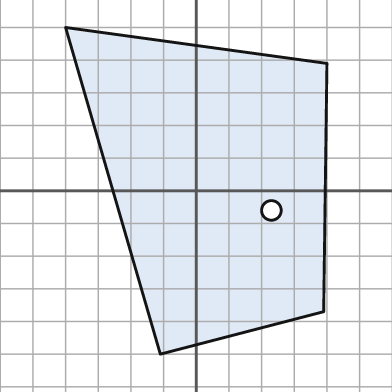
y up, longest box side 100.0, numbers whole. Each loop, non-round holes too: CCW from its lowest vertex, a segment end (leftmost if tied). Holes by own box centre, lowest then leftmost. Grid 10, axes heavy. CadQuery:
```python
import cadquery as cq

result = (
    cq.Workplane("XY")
    .moveTo(-11.0, -50.0)
    .lineTo(39.0, -37.0)
    .lineTo(40.0, 39.0)
    .lineTo(-40.0, 50.0)
    .close()
    .moveTo(23.0, -6.0)
    .circle(3.0)
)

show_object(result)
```